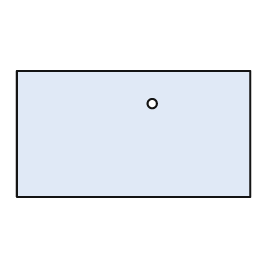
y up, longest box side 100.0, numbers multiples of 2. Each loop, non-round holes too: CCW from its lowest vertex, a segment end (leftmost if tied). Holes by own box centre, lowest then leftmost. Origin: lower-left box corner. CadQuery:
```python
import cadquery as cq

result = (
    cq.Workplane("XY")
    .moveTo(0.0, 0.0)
    .lineTo(100.0, 0.0)
    .lineTo(100.0, 54.0)
    .lineTo(0.0, 54.0)
    .close()
    .moveTo(58.0, 40.0)
    .circle(2.0)
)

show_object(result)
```